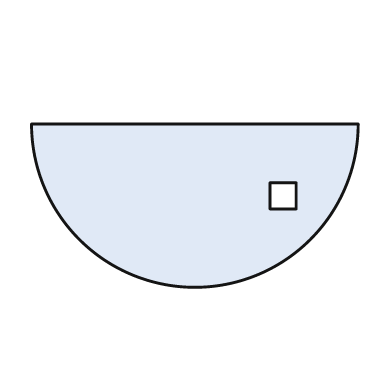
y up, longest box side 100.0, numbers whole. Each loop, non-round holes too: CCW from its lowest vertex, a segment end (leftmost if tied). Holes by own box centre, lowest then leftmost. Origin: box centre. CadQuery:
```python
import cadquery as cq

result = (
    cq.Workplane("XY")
    .moveTo(-50.0, 25.0)
    .threePointArc((0.0, -25.0), (50.0, 25.0))
    .close()
    .moveTo(23.0, -1.0)
    .lineTo(31.0, -1.0)
    .lineTo(31.0, 7.0)
    .lineTo(23.0, 7.0)
    .close()
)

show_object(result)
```